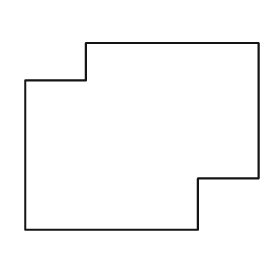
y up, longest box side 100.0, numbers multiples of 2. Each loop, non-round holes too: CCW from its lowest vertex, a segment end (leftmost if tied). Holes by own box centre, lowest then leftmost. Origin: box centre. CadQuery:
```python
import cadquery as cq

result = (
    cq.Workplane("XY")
    .moveTo(-50.0, -40.0)
    .lineTo(24.0, -40.0)
    .lineTo(24.0, -18.0)
    .lineTo(50.0, -18.0)
    .lineTo(50.0, 40.0)
    .lineTo(-24.0, 40.0)
    .lineTo(-24.0, 24.0)
    .lineTo(-50.0, 24.0)
    .close()
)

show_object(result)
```